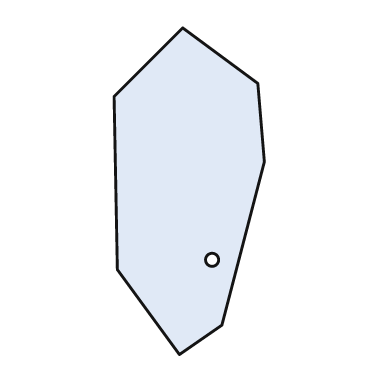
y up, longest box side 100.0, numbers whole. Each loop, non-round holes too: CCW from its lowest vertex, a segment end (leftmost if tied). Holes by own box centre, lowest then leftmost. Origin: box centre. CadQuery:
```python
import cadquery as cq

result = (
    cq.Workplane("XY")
    .moveTo(-3.0, -50.0)
    .lineTo(10.0, -41.0)
    .lineTo(23.0, 9.0)
    .lineTo(21.0, 33.0)
    .lineTo(-2.0, 50.0)
    .lineTo(-23.0, 29.0)
    .lineTo(-22.0, -24.0)
    .close()
    .moveTo(7.0, -21.0)
    .circle(2.0)
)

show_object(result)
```